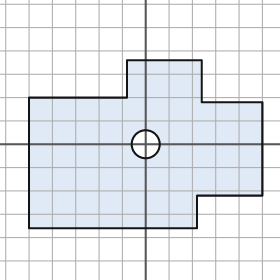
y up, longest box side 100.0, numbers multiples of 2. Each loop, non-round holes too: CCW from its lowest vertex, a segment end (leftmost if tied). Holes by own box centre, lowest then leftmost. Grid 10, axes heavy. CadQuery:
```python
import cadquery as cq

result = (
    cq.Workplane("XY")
    .moveTo(-50.0, -36.0)
    .lineTo(22.0, -36.0)
    .lineTo(22.0, -22.0)
    .lineTo(50.0, -22.0)
    .lineTo(50.0, 18.0)
    .lineTo(24.0, 18.0)
    .lineTo(24.0, 36.0)
    .lineTo(-8.0, 36.0)
    .lineTo(-8.0, 20.0)
    .lineTo(-50.0, 20.0)
    .close()
    .moveTo(0.0, 0.0)
    .circle(6.0)
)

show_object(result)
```